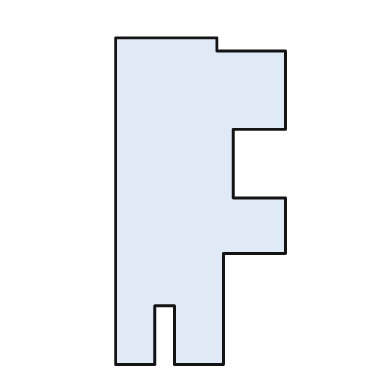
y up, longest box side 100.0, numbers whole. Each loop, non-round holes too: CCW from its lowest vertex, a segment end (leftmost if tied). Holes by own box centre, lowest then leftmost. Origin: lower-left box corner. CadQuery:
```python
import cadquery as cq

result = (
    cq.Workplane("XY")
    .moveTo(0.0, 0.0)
    .lineTo(12.0, 0.0)
    .lineTo(12.0, 18.0)
    .lineTo(18.0, 18.0)
    .lineTo(18.0, 0.0)
    .lineTo(33.0, 0.0)
    .lineTo(33.0, 34.0)
    .lineTo(52.0, 34.0)
    .lineTo(52.0, 51.0)
    .lineTo(36.0, 51.0)
    .lineTo(36.0, 72.0)
    .lineTo(52.0, 72.0)
    .lineTo(52.0, 96.0)
    .lineTo(31.0, 96.0)
    .lineTo(31.0, 100.0)
    .lineTo(0.0, 100.0)
    .close()
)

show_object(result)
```